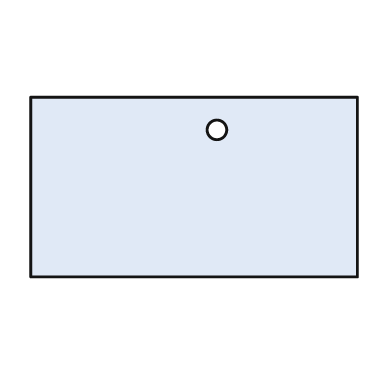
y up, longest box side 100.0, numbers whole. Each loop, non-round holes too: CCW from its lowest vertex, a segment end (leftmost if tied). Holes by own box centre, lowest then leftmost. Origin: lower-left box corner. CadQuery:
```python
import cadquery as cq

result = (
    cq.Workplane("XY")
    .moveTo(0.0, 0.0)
    .lineTo(100.0, 0.0)
    .lineTo(100.0, 55.0)
    .lineTo(0.0, 55.0)
    .close()
    .moveTo(57.0, 45.0)
    .circle(3.0)
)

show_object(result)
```